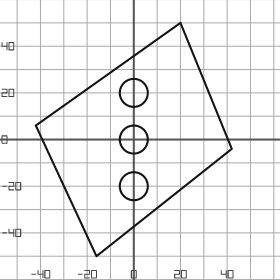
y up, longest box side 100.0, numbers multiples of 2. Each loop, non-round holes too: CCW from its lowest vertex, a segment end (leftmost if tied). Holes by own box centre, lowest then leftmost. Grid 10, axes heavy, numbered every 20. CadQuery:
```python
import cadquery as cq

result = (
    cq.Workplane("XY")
    .moveTo(-16.0, -50.0)
    .lineTo(42.0, -4.0)
    .lineTo(20.0, 50.0)
    .lineTo(-42.0, 6.0)
    .close()
    .moveTo(0.0, -20.0)
    .circle(6.0)
    .moveTo(0.0, 0.0)
    .circle(6.0)
    .moveTo(0.0, 20.0)
    .circle(6.0)
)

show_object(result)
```